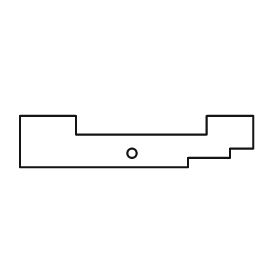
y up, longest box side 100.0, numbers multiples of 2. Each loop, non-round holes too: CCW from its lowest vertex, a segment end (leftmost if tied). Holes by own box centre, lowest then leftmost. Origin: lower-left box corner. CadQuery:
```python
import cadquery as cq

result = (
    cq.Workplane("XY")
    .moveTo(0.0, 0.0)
    .lineTo(72.0, 0.0)
    .lineTo(72.0, 4.0)
    .lineTo(90.0, 4.0)
    .lineTo(90.0, 8.0)
    .lineTo(100.0, 8.0)
    .lineTo(100.0, 22.0)
    .lineTo(80.0, 22.0)
    .lineTo(80.0, 14.0)
    .lineTo(24.0, 14.0)
    .lineTo(24.0, 22.0)
    .lineTo(0.0, 22.0)
    .close()
    .moveTo(48.0, 6.0)
    .circle(2.0)
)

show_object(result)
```